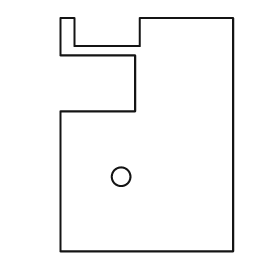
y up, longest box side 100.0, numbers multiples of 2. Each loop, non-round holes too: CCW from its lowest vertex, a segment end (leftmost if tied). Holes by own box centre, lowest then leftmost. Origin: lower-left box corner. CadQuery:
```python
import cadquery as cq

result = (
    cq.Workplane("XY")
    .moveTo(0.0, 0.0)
    .lineTo(74.0, 0.0)
    .lineTo(74.0, 100.0)
    .lineTo(34.0, 100.0)
    .lineTo(34.0, 88.0)
    .lineTo(6.0, 88.0)
    .lineTo(6.0, 100.0)
    .lineTo(0.0, 100.0)
    .lineTo(0.0, 84.0)
    .lineTo(32.0, 84.0)
    .lineTo(32.0, 60.0)
    .lineTo(0.0, 60.0)
    .close()
    .moveTo(26.0, 32.0)
    .circle(4.0)
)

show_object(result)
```